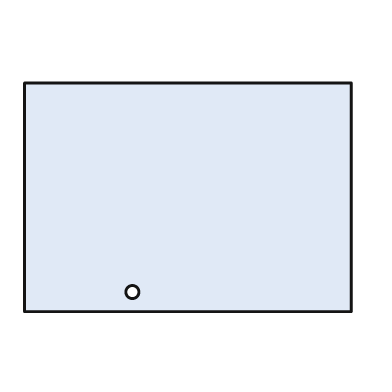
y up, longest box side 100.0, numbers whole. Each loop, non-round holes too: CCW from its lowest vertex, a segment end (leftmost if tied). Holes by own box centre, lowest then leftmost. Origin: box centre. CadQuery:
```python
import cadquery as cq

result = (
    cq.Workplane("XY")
    .moveTo(-50.0, -35.0)
    .lineTo(50.0, -35.0)
    .lineTo(50.0, 35.0)
    .lineTo(-50.0, 35.0)
    .close()
    .moveTo(-17.0, -29.0)
    .circle(2.0)
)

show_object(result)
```